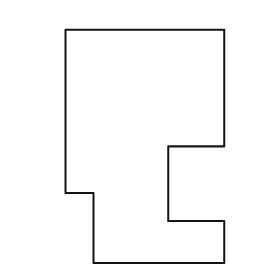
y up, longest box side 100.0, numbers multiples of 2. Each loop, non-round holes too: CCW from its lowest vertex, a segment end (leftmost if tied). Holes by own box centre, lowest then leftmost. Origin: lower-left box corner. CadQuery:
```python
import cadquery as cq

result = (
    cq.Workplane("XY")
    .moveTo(12.0, 0.0)
    .lineTo(68.0, 0.0)
    .lineTo(68.0, 18.0)
    .lineTo(44.0, 18.0)
    .lineTo(44.0, 50.0)
    .lineTo(68.0, 50.0)
    .lineTo(68.0, 100.0)
    .lineTo(0.0, 100.0)
    .lineTo(0.0, 30.0)
    .lineTo(12.0, 30.0)
    .close()
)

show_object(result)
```